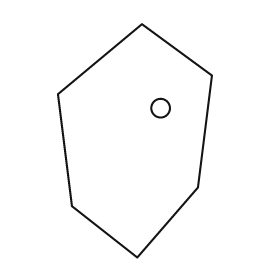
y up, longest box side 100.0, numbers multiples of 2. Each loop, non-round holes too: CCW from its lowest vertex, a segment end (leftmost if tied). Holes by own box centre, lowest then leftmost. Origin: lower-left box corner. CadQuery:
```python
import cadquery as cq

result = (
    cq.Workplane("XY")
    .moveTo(34.0, 0.0)
    .lineTo(60.0, 30.0)
    .lineTo(66.0, 78.0)
    .lineTo(36.0, 100.0)
    .lineTo(0.0, 70.0)
    .lineTo(6.0, 22.0)
    .close()
    .moveTo(44.0, 64.0)
    .circle(4.0)
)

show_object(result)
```